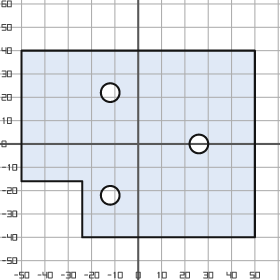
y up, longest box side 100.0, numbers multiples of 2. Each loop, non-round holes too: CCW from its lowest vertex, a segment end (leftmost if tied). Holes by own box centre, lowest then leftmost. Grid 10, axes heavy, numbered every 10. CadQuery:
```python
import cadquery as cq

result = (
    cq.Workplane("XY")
    .moveTo(-24.0, -40.0)
    .lineTo(50.0, -40.0)
    .lineTo(50.0, 40.0)
    .lineTo(-50.0, 40.0)
    .lineTo(-50.0, -16.0)
    .lineTo(-24.0, -16.0)
    .close()
    .moveTo(-12.0, -22.0)
    .circle(4.0)
    .moveTo(26.0, 0.0)
    .circle(4.0)
    .moveTo(-12.0, 22.0)
    .circle(4.0)
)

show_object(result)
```